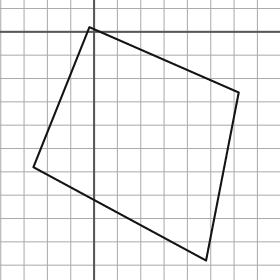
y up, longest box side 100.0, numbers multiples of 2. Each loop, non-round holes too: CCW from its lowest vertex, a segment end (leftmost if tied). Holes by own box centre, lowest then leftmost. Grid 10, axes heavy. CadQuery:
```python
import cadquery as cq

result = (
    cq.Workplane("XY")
    .moveTo(48.0, -98.0)
    .lineTo(62.0, -26.0)
    .lineTo(-2.0, 2.0)
    .lineTo(-26.0, -58.0)
    .close()
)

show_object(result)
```